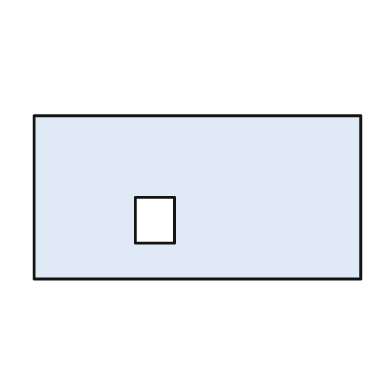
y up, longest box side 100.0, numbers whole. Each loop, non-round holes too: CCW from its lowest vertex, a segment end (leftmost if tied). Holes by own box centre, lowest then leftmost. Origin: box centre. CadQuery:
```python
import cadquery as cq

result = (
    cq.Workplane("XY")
    .moveTo(-50.0, -25.0)
    .lineTo(50.0, -25.0)
    .lineTo(50.0, 25.0)
    .lineTo(-50.0, 25.0)
    .close()
    .moveTo(-19.0, -14.0)
    .lineTo(-7.0, -14.0)
    .lineTo(-7.0, 0.0)
    .lineTo(-19.0, 0.0)
    .close()
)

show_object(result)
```